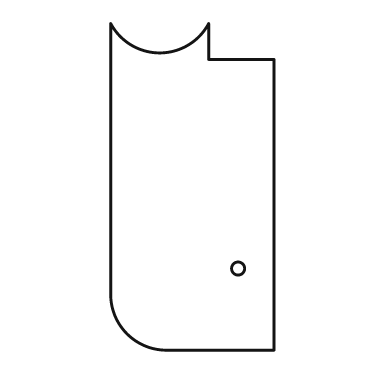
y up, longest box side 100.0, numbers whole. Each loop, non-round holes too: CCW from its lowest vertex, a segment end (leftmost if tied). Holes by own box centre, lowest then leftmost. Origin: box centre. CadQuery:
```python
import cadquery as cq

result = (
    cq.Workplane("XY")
    .moveTo(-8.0, -50.0)
    .lineTo(25.0, -50.0)
    .lineTo(25.0, 39.0)
    .lineTo(5.0, 39.0)
    .lineTo(5.0, 50.0)
    .threePointArc((-10.0, 41.0), (-25.0, 50.0))
    .lineTo(-25.0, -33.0)
    .threePointArc((-20.0, -45.0), (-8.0, -50.0))
    .close()
    .moveTo(14.0, -25.0)
    .circle(2.0)
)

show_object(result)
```